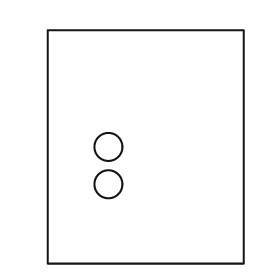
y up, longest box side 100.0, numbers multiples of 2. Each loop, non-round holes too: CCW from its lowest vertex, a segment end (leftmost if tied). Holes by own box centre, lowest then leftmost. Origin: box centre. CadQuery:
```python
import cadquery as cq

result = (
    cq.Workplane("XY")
    .moveTo(-42.0, -50.0)
    .lineTo(42.0, -50.0)
    .lineTo(42.0, 50.0)
    .lineTo(-42.0, 50.0)
    .close()
    .moveTo(-16.0, -16.0)
    .circle(6.0)
    .moveTo(-16.0, 0.0)
    .circle(6.0)
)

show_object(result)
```